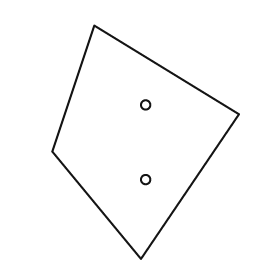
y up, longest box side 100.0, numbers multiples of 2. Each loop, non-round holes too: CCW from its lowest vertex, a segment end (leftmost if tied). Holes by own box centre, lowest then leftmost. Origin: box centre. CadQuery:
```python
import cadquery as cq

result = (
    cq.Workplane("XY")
    .moveTo(-2.0, -50.0)
    .lineTo(40.0, 12.0)
    .lineTo(-22.0, 50.0)
    .lineTo(-40.0, -4.0)
    .close()
    .moveTo(0.0, -16.0)
    .circle(2.0)
    .moveTo(0.0, 16.0)
    .circle(2.0)
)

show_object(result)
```